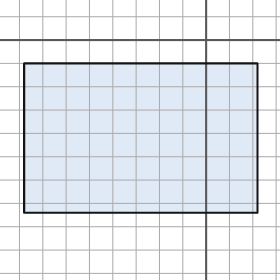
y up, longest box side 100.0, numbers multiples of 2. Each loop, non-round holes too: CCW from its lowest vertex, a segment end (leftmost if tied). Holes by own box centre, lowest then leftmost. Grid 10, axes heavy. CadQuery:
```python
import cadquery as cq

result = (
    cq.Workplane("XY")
    .moveTo(-78.0, -74.0)
    .lineTo(22.0, -74.0)
    .lineTo(22.0, -10.0)
    .lineTo(-78.0, -10.0)
    .close()
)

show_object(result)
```